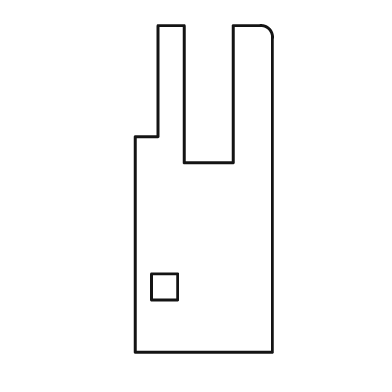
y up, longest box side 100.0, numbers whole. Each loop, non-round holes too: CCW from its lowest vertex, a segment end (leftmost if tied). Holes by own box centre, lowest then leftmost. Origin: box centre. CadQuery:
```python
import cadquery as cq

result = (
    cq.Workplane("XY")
    .moveTo(-21.0, -50.0)
    .lineTo(21.0, -50.0)
    .lineTo(21.0, 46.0)
    .threePointArc((20.0, 49.0), (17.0, 50.0))
    .lineTo(9.0, 50.0)
    .lineTo(9.0, 8.0)
    .lineTo(-6.0, 8.0)
    .lineTo(-6.0, 50.0)
    .lineTo(-14.0, 50.0)
    .lineTo(-14.0, 16.0)
    .lineTo(-21.0, 16.0)
    .close()
    .moveTo(-16.0, -34.0)
    .lineTo(-8.0, -34.0)
    .lineTo(-8.0, -26.0)
    .lineTo(-16.0, -26.0)
    .close()
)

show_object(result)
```